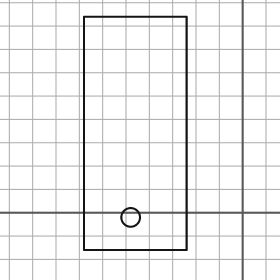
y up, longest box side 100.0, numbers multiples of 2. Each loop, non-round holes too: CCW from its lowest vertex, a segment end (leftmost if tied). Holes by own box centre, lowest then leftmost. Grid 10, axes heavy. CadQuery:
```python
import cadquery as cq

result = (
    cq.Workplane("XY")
    .moveTo(-68.0, -16.0)
    .lineTo(-24.0, -16.0)
    .lineTo(-24.0, 84.0)
    .lineTo(-68.0, 84.0)
    .close()
    .moveTo(-48.0, -2.0)
    .circle(4.0)
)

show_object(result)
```